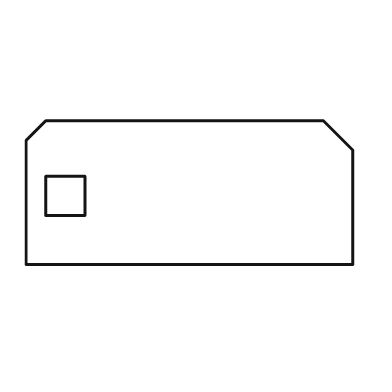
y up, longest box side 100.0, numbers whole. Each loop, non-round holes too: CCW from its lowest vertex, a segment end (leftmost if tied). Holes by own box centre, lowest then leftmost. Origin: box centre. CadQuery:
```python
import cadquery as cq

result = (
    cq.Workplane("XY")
    .moveTo(-50.0, -22.0)
    .lineTo(50.0, -22.0)
    .lineTo(50.0, 13.0)
    .lineTo(41.0, 22.0)
    .lineTo(-44.0, 22.0)
    .lineTo(-50.0, 16.0)
    .close()
    .moveTo(-44.0, -7.0)
    .lineTo(-32.0, -7.0)
    .lineTo(-32.0, 5.0)
    .lineTo(-44.0, 5.0)
    .close()
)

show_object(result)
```